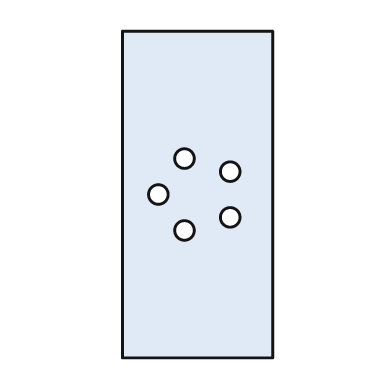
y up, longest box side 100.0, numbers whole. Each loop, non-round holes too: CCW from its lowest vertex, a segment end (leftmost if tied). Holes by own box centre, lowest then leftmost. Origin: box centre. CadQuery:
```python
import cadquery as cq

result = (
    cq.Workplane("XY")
    .moveTo(-23.0, -50.0)
    .lineTo(23.0, -50.0)
    .lineTo(23.0, 50.0)
    .lineTo(-23.0, 50.0)
    .close()
    .moveTo(-4.0, -11.0)
    .circle(3.0)
    .moveTo(10.0, -7.0)
    .circle(3.0)
    .moveTo(-12.0, 0.0)
    .circle(3.0)
    .moveTo(10.0, 7.0)
    .circle(3.0)
    .moveTo(-4.0, 11.0)
    .circle(3.0)
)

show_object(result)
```